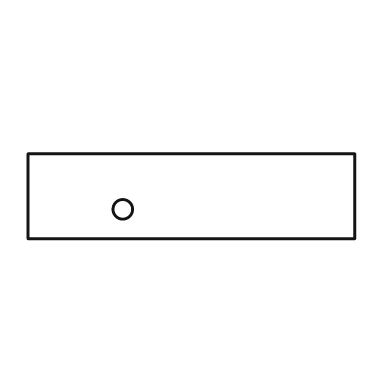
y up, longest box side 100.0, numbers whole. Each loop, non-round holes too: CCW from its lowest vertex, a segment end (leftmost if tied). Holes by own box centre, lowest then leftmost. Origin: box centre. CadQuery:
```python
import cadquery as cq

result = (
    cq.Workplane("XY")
    .moveTo(-50.0, -13.0)
    .lineTo(50.0, -13.0)
    .lineTo(50.0, 13.0)
    .lineTo(-50.0, 13.0)
    .close()
    .moveTo(-21.0, -4.0)
    .circle(3.0)
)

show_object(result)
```